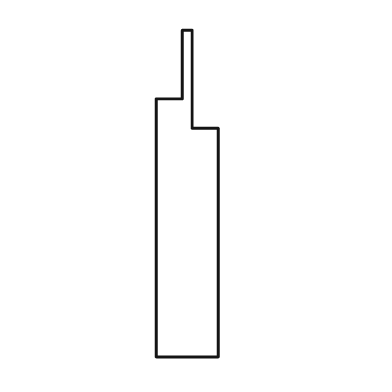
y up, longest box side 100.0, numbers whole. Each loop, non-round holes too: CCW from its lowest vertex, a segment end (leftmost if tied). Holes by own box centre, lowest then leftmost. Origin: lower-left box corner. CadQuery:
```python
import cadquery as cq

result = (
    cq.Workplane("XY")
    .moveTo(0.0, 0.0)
    .lineTo(19.0, 0.0)
    .lineTo(19.0, 70.0)
    .lineTo(11.0, 70.0)
    .lineTo(11.0, 100.0)
    .lineTo(8.0, 100.0)
    .lineTo(8.0, 79.0)
    .lineTo(0.0, 79.0)
    .close()
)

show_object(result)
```